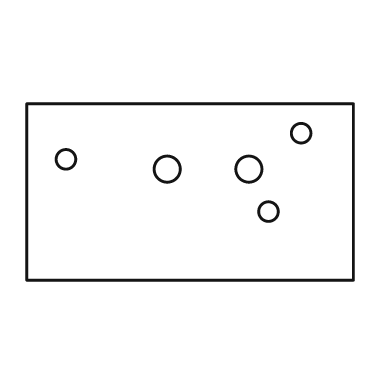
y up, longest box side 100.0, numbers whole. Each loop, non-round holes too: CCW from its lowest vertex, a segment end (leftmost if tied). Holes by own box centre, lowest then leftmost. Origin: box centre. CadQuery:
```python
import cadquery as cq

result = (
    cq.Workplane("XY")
    .moveTo(-50.0, -27.0)
    .lineTo(50.0, -27.0)
    .lineTo(50.0, 27.0)
    .lineTo(-50.0, 27.0)
    .close()
    .moveTo(24.0, -6.0)
    .circle(3.0)
    .moveTo(-7.0, 7.0)
    .circle(4.0)
    .moveTo(18.0, 7.0)
    .circle(4.0)
    .moveTo(-38.0, 10.0)
    .circle(3.0)
    .moveTo(34.0, 18.0)
    .circle(3.0)
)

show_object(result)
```